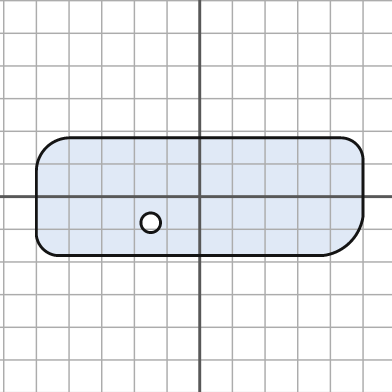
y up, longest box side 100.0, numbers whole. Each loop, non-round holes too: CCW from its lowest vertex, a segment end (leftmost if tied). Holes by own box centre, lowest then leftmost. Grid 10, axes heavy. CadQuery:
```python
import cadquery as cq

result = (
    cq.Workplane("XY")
    .moveTo(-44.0, -18.0)
    .lineTo(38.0, -18.0)
    .threePointArc((46.0, -14.0), (50.0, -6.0))
    .lineTo(50.0, 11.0)
    .threePointArc((48.0, 16.0), (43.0, 18.0))
    .lineTo(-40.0, 18.0)
    .threePointArc((-47.0, 15.0), (-50.0, 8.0))
    .lineTo(-50.0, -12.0)
    .threePointArc((-48.0, -16.0), (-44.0, -18.0))
    .close()
    .moveTo(-15.0, -8.0)
    .circle(3.0)
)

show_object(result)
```